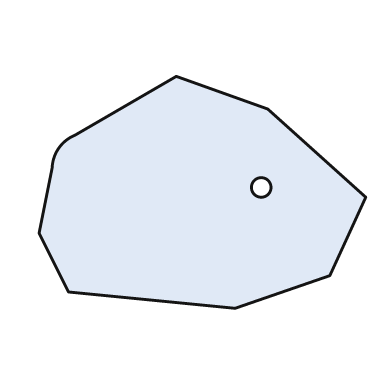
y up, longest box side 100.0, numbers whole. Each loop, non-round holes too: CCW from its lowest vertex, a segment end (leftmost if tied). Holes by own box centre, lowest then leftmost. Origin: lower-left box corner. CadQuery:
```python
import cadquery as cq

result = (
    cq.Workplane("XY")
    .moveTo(60.0, 0.0)
    .lineTo(89.0, 10.0)
    .lineTo(100.0, 34.0)
    .lineTo(70.0, 61.0)
    .lineTo(42.0, 71.0)
    .lineTo(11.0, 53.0)
    .threePointArc((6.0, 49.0), (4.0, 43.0))
    .lineTo(0.0, 23.0)
    .lineTo(9.0, 5.0)
    .close()
    .moveTo(68.0, 37.0)
    .circle(3.0)
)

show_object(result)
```